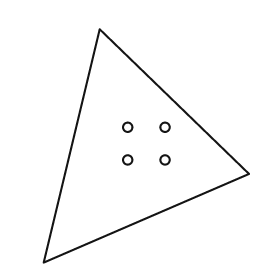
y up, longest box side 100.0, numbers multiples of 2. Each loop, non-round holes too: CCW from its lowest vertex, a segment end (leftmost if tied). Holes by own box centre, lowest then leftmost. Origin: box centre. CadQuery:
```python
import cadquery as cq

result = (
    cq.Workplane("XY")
    .moveTo(-44.0, -50.0)
    .lineTo(44.0, -12.0)
    .lineTo(-20.0, 50.0)
    .close()
    .moveTo(-8.0, -6.0)
    .circle(2.0)
    .moveTo(8.0, -6.0)
    .circle(2.0)
    .moveTo(-8.0, 8.0)
    .circle(2.0)
    .moveTo(8.0, 8.0)
    .circle(2.0)
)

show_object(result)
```